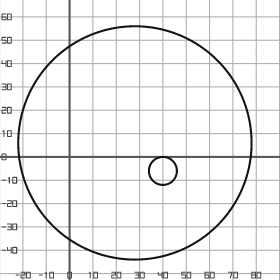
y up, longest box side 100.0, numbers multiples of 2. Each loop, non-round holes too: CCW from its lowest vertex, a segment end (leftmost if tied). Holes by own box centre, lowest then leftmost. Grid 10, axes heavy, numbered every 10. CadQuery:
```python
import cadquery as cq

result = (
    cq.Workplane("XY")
    .moveTo(28.0, 6.0)
    .circle(50.0)
    .moveTo(40.0, -6.0)
    .circle(6.0)
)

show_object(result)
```